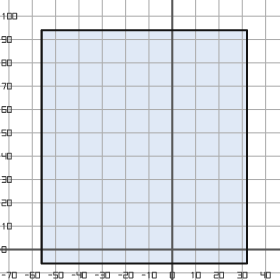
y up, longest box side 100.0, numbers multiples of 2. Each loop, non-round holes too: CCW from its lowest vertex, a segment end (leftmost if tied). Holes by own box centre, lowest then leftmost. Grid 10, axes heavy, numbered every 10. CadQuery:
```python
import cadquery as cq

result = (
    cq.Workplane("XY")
    .moveTo(-56.0, -6.0)
    .lineTo(32.0, -6.0)
    .lineTo(32.0, 94.0)
    .lineTo(-56.0, 94.0)
    .close()
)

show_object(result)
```